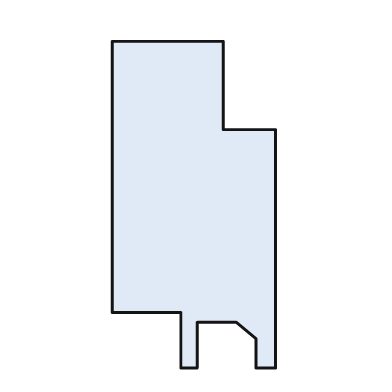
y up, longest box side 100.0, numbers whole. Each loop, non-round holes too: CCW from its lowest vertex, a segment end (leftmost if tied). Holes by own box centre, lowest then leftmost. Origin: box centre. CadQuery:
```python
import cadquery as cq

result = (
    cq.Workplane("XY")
    .moveTo(-4.0, -50.0)
    .lineTo(1.0, -50.0)
    .lineTo(1.0, -36.0)
    .lineTo(13.0, -36.0)
    .lineTo(19.0, -41.0)
    .lineTo(19.0, -50.0)
    .lineTo(25.0, -50.0)
    .lineTo(25.0, 23.0)
    .lineTo(9.0, 23.0)
    .lineTo(9.0, 50.0)
    .lineTo(-25.0, 50.0)
    .lineTo(-25.0, -33.0)
    .lineTo(-4.0, -33.0)
    .close()
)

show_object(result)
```